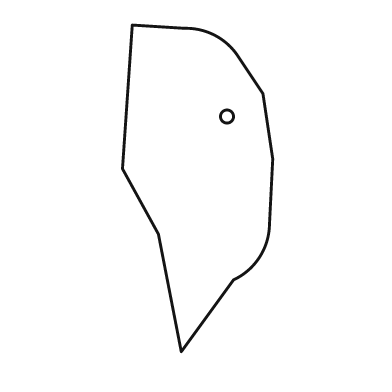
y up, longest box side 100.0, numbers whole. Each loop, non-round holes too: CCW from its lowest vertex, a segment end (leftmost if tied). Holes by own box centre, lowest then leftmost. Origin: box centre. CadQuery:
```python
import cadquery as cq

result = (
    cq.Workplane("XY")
    .moveTo(-5.0, -50.0)
    .lineTo(11.0, -28.0)
    .threePointArc((19.0, -21.0), (22.0, -11.0))
    .lineTo(23.0, 9.0)
    .lineTo(20.0, 29.0)
    .lineTo(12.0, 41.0)
    .threePointArc((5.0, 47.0), (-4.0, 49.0))
    .lineTo(-20.0, 50.0)
    .lineTo(-23.0, 6.0)
    .lineTo(-12.0, -14.0)
    .close()
    .moveTo(9.0, 22.0)
    .circle(2.0)
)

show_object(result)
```